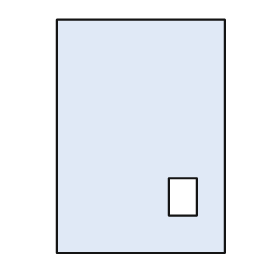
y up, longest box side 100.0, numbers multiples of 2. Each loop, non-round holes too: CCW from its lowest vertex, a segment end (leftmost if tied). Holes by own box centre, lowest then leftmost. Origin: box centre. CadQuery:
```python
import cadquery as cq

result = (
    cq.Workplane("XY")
    .moveTo(-36.0, -50.0)
    .lineTo(36.0, -50.0)
    .lineTo(36.0, 50.0)
    .lineTo(-36.0, 50.0)
    .close()
    .moveTo(12.0, -34.0)
    .lineTo(24.0, -34.0)
    .lineTo(24.0, -18.0)
    .lineTo(12.0, -18.0)
    .close()
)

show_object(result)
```